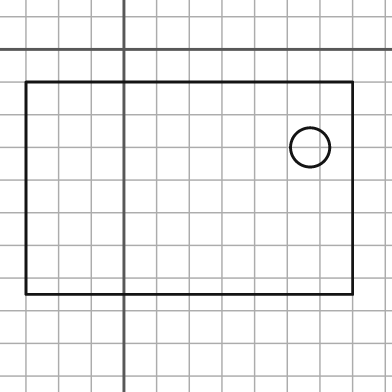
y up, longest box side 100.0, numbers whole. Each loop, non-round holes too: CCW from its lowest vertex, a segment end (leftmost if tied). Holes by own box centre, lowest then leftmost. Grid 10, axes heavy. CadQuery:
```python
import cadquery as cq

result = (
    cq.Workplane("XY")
    .moveTo(-30.0, -75.0)
    .lineTo(70.0, -75.0)
    .lineTo(70.0, -10.0)
    .lineTo(-30.0, -10.0)
    .close()
    .moveTo(57.0, -30.0)
    .circle(6.0)
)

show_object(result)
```